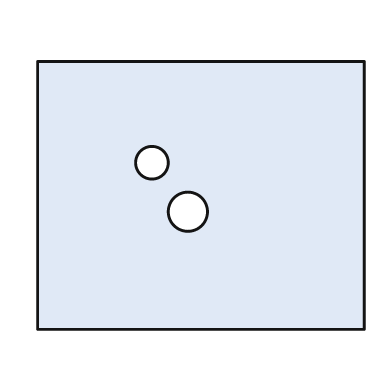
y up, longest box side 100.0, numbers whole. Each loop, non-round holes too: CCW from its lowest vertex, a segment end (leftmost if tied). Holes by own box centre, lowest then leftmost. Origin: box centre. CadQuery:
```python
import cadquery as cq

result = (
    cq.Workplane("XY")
    .moveTo(-50.0, -41.0)
    .lineTo(50.0, -41.0)
    .lineTo(50.0, 41.0)
    .lineTo(-50.0, 41.0)
    .close()
    .moveTo(-4.0, -5.0)
    .circle(6.0)
    .moveTo(-15.0, 10.0)
    .circle(5.0)
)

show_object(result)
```